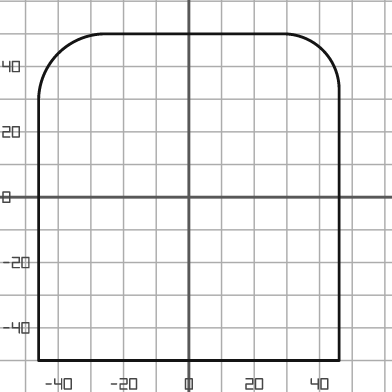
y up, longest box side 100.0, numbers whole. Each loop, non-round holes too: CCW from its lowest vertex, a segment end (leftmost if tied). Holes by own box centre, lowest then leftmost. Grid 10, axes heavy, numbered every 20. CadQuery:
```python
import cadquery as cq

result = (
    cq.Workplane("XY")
    .moveTo(-46.0, -50.0)
    .lineTo(46.0, -50.0)
    .lineTo(46.0, 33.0)
    .threePointArc((41.0, 45.0), (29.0, 50.0))
    .lineTo(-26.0, 50.0)
    .threePointArc((-40.0, 44.0), (-46.0, 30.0))
    .close()
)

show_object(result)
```